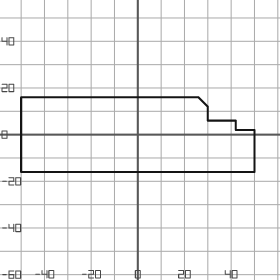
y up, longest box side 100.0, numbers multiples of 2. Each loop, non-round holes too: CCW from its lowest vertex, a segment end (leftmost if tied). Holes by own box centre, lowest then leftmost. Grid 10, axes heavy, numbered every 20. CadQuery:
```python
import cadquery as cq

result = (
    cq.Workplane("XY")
    .moveTo(-50.0, -16.0)
    .lineTo(50.0, -16.0)
    .lineTo(50.0, 2.0)
    .lineTo(42.0, 2.0)
    .lineTo(42.0, 6.0)
    .lineTo(30.0, 6.0)
    .lineTo(30.0, 12.0)
    .lineTo(26.0, 16.0)
    .lineTo(-50.0, 16.0)
    .close()
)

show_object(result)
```